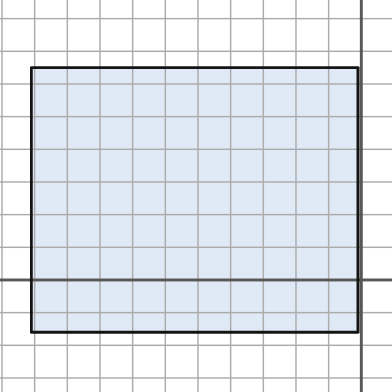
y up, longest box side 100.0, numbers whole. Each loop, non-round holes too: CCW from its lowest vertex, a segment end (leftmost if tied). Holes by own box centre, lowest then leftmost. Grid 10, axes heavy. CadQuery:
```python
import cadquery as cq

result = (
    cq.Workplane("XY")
    .moveTo(-101.0, -16.0)
    .lineTo(-1.0, -16.0)
    .lineTo(-1.0, 65.0)
    .lineTo(-101.0, 65.0)
    .close()
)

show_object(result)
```